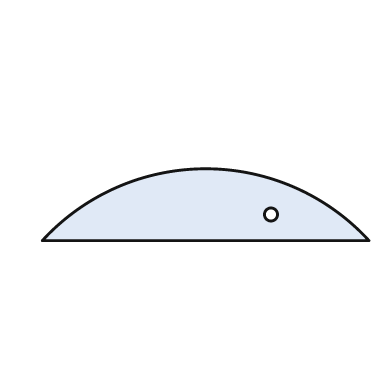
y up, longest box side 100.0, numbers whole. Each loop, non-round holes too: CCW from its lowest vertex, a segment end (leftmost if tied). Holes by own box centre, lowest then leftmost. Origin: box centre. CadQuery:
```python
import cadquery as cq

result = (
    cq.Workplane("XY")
    .moveTo(-50.0, -11.0)
    .lineTo(50.0, -11.0)
    .threePointArc((0.0, 11.0), (-50.0, -11.0))
    .close()
    .moveTo(20.0, -3.0)
    .circle(2.0)
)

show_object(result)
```